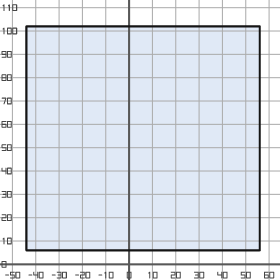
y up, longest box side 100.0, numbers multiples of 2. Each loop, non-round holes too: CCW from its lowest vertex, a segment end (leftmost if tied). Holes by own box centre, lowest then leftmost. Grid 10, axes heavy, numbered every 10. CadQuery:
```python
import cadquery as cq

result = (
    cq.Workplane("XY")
    .moveTo(-44.0, 6.0)
    .lineTo(56.0, 6.0)
    .lineTo(56.0, 102.0)
    .lineTo(-44.0, 102.0)
    .close()
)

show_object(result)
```